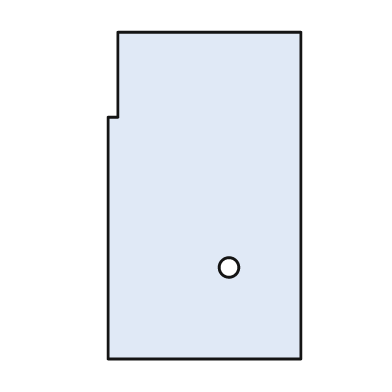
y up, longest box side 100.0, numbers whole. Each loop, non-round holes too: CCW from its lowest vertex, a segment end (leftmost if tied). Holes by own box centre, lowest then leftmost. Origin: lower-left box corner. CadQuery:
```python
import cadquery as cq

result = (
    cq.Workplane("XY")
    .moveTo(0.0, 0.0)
    .lineTo(59.0, 0.0)
    .lineTo(59.0, 100.0)
    .lineTo(3.0, 100.0)
    .lineTo(3.0, 74.0)
    .lineTo(0.0, 74.0)
    .close()
    .moveTo(37.0, 28.0)
    .circle(3.0)
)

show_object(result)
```